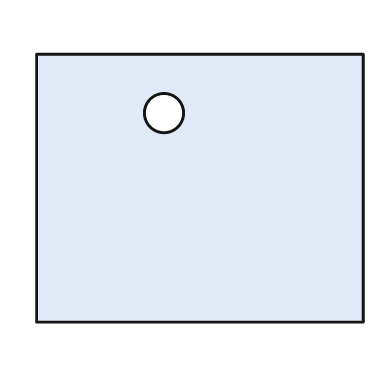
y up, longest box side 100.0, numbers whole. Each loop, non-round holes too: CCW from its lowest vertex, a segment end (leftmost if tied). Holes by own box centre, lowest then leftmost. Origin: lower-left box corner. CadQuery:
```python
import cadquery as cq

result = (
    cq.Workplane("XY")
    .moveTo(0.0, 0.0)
    .lineTo(100.0, 0.0)
    .lineTo(100.0, 82.0)
    .lineTo(0.0, 82.0)
    .close()
    .moveTo(39.0, 64.0)
    .circle(6.0)
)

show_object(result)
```